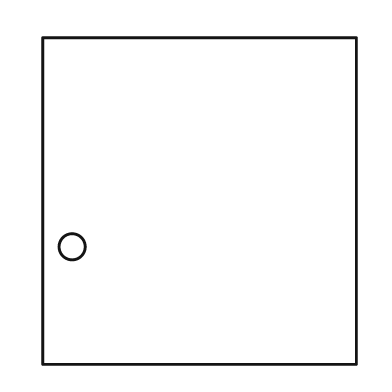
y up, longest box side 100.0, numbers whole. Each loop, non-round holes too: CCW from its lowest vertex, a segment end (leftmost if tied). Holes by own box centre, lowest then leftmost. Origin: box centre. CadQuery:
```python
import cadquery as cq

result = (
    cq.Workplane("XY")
    .moveTo(-48.0, -50.0)
    .lineTo(48.0, -50.0)
    .lineTo(48.0, 50.0)
    .lineTo(-48.0, 50.0)
    .close()
    .moveTo(-39.0, -14.0)
    .circle(4.0)
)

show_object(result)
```